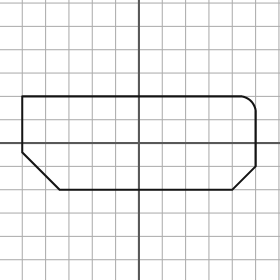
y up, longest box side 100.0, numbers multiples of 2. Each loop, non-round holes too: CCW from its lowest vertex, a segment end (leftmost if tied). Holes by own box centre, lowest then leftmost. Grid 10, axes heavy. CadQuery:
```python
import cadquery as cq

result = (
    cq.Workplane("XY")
    .moveTo(-34.0, -20.0)
    .lineTo(40.0, -20.0)
    .lineTo(50.0, -10.0)
    .lineTo(50.0, 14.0)
    .threePointArc((48.0, 18.0), (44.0, 20.0))
    .lineTo(-50.0, 20.0)
    .lineTo(-50.0, -4.0)
    .close()
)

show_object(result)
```